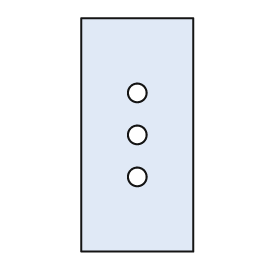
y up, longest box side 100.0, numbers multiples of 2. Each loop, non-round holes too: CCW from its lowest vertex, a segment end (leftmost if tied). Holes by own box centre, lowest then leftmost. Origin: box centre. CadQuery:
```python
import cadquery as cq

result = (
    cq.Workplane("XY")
    .moveTo(-24.0, -50.0)
    .lineTo(24.0, -50.0)
    .lineTo(24.0, 50.0)
    .lineTo(-24.0, 50.0)
    .close()
    .moveTo(0.0, -18.0)
    .circle(4.0)
    .moveTo(0.0, 0.0)
    .circle(4.0)
    .moveTo(0.0, 18.0)
    .circle(4.0)
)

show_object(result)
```